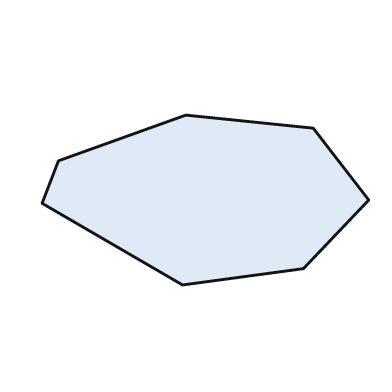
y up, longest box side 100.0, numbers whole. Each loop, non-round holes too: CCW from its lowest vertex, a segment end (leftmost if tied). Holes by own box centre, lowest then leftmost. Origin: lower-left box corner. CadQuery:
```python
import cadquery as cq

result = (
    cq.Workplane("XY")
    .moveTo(43.0, 0.0)
    .lineTo(80.0, 5.0)
    .lineTo(100.0, 26.0)
    .lineTo(83.0, 48.0)
    .lineTo(44.0, 52.0)
    .lineTo(5.0, 38.0)
    .lineTo(0.0, 25.0)
    .close()
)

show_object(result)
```